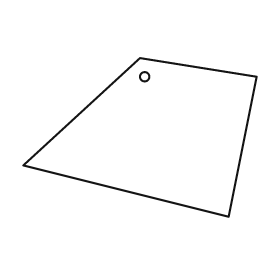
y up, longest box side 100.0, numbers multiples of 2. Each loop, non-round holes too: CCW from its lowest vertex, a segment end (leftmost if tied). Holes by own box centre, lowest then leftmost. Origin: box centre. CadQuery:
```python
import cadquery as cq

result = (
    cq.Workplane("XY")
    .moveTo(38.0, -34.0)
    .lineTo(50.0, 26.0)
    .lineTo(0.0, 34.0)
    .lineTo(-50.0, -12.0)
    .close()
    .moveTo(2.0, 26.0)
    .circle(2.0)
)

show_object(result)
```